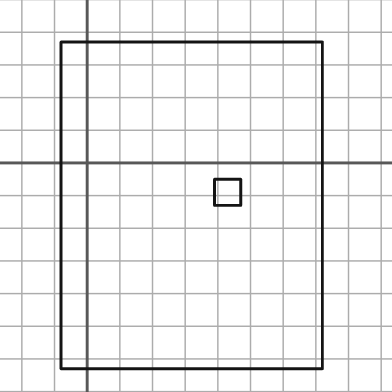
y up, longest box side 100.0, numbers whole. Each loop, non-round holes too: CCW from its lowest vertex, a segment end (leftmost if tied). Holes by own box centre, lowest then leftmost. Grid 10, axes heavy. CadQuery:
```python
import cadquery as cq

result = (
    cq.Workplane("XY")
    .moveTo(-8.0, -63.0)
    .lineTo(72.0, -63.0)
    .lineTo(72.0, 37.0)
    .lineTo(-8.0, 37.0)
    .close()
    .moveTo(39.0, -13.0)
    .lineTo(47.0, -13.0)
    .lineTo(47.0, -5.0)
    .lineTo(39.0, -5.0)
    .close()
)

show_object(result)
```